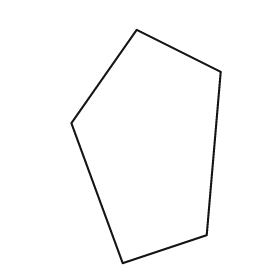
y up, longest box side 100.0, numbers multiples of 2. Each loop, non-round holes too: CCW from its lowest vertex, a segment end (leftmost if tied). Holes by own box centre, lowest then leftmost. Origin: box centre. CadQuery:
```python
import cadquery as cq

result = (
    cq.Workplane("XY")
    .moveTo(-10.0, -50.0)
    .lineTo(26.0, -38.0)
    .lineTo(32.0, 32.0)
    .lineTo(-4.0, 50.0)
    .lineTo(-32.0, 10.0)
    .close()
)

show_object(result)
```